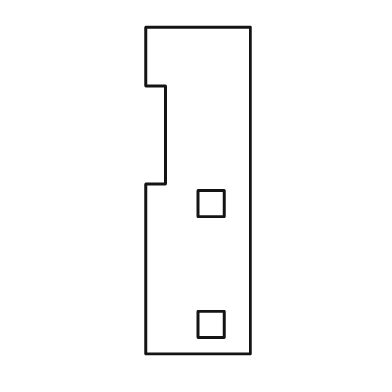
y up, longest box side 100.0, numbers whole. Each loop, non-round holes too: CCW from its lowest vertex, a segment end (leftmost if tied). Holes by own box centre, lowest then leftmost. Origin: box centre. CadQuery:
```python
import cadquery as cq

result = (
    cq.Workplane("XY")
    .moveTo(-16.0, -50.0)
    .lineTo(16.0, -50.0)
    .lineTo(16.0, 50.0)
    .lineTo(-16.0, 50.0)
    .lineTo(-16.0, 32.0)
    .lineTo(-10.0, 32.0)
    .lineTo(-10.0, 2.0)
    .lineTo(-16.0, 2.0)
    .close()
    .moveTo(0.0, -45.0)
    .lineTo(8.0, -45.0)
    .lineTo(8.0, -37.0)
    .lineTo(0.0, -37.0)
    .close()
    .moveTo(0.0, -8.0)
    .lineTo(8.0, -8.0)
    .lineTo(8.0, 0.0)
    .lineTo(0.0, 0.0)
    .close()
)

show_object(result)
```